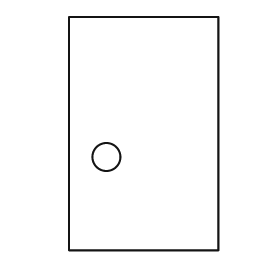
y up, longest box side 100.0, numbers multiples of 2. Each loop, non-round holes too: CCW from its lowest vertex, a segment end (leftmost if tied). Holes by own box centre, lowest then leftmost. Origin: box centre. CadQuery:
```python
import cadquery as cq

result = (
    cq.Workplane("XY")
    .moveTo(-32.0, -50.0)
    .lineTo(32.0, -50.0)
    .lineTo(32.0, 50.0)
    .lineTo(-32.0, 50.0)
    .close()
    .moveTo(-16.0, -10.0)
    .circle(6.0)
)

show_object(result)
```